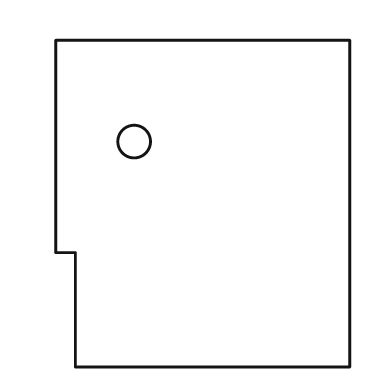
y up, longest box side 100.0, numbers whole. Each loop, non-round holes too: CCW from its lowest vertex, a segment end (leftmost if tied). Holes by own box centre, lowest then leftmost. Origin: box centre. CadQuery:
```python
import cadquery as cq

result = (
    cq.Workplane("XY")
    .moveTo(-39.0, -50.0)
    .lineTo(45.0, -50.0)
    .lineTo(45.0, 50.0)
    .lineTo(-45.0, 50.0)
    .lineTo(-45.0, -15.0)
    .lineTo(-39.0, -15.0)
    .close()
    .moveTo(-21.0, 19.0)
    .circle(5.0)
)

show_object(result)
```